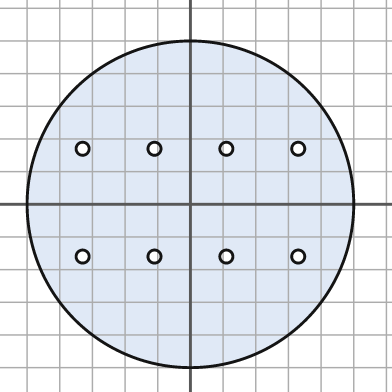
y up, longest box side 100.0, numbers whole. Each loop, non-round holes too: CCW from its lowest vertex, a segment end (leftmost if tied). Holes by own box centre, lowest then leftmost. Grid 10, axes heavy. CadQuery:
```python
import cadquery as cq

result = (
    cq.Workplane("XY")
    .moveTo(0.0, 0.0)
    .circle(50.0)
    .moveTo(-33.0, -16.0)
    .circle(2.0)
    .moveTo(-11.0, -16.0)
    .circle(2.0)
    .moveTo(11.0, -16.0)
    .circle(2.0)
    .moveTo(33.0, -16.0)
    .circle(2.0)
    .moveTo(-33.0, 17.0)
    .circle(2.0)
    .moveTo(-11.0, 17.0)
    .circle(2.0)
    .moveTo(11.0, 17.0)
    .circle(2.0)
    .moveTo(33.0, 17.0)
    .circle(2.0)
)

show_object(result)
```